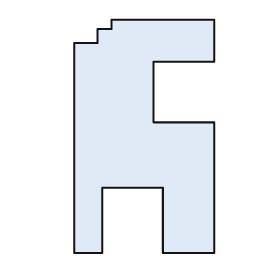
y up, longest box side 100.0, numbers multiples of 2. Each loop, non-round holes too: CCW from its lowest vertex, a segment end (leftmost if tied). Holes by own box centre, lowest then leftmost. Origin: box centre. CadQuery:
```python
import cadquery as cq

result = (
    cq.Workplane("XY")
    .moveTo(-30.0, -50.0)
    .lineTo(-18.0, -50.0)
    .lineTo(-18.0, -22.0)
    .lineTo(8.0, -22.0)
    .lineTo(8.0, -50.0)
    .lineTo(30.0, -50.0)
    .lineTo(30.0, 6.0)
    .lineTo(4.0, 6.0)
    .lineTo(4.0, 32.0)
    .lineTo(30.0, 32.0)
    .lineTo(30.0, 50.0)
    .lineTo(-14.0, 50.0)
    .lineTo(-14.0, 46.0)
    .lineTo(-20.0, 46.0)
    .lineTo(-20.0, 40.0)
    .lineTo(-30.0, 40.0)
    .close()
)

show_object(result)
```